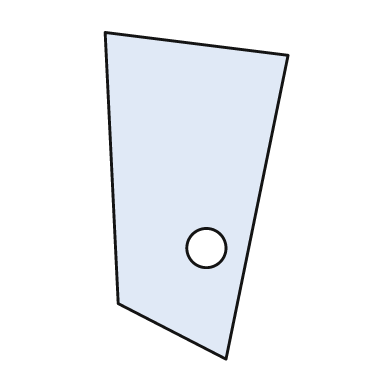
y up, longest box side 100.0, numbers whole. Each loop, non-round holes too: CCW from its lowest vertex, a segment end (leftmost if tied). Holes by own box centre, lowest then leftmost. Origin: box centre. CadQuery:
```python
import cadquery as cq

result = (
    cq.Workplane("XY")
    .moveTo(9.0, -50.0)
    .lineTo(28.0, 43.0)
    .lineTo(-28.0, 50.0)
    .lineTo(-24.0, -33.0)
    .close()
    .moveTo(3.0, -16.0)
    .circle(6.0)
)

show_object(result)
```